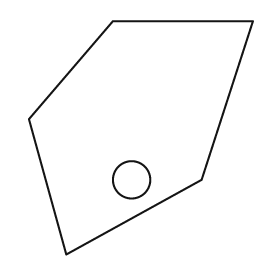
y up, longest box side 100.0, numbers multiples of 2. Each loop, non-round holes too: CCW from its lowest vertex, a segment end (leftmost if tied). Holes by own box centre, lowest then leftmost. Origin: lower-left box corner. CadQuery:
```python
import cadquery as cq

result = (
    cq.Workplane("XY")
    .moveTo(16.0, 0.0)
    .lineTo(74.0, 32.0)
    .lineTo(96.0, 100.0)
    .lineTo(36.0, 100.0)
    .lineTo(0.0, 58.0)
    .close()
    .moveTo(44.0, 32.0)
    .circle(8.0)
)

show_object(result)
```